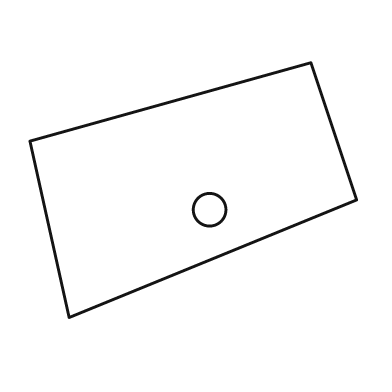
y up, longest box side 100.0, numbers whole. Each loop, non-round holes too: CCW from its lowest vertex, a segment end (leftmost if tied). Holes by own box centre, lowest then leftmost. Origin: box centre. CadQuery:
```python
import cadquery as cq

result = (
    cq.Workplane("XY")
    .moveTo(-38.0, -39.0)
    .lineTo(50.0, -3.0)
    .lineTo(36.0, 39.0)
    .lineTo(-50.0, 15.0)
    .close()
    .moveTo(5.0, -6.0)
    .circle(5.0)
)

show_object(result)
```